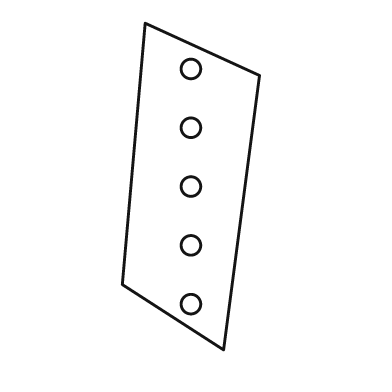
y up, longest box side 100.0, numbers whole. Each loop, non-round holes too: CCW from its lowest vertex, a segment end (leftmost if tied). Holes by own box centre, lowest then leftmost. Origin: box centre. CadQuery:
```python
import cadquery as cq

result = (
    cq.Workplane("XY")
    .moveTo(10.0, -50.0)
    .lineTo(21.0, 34.0)
    .lineTo(-14.0, 50.0)
    .lineTo(-21.0, -30.0)
    .close()
    .moveTo(0.0, -36.0)
    .circle(3.0)
    .moveTo(0.0, -18.0)
    .circle(3.0)
    .moveTo(0.0, 0.0)
    .circle(3.0)
    .moveTo(0.0, 18.0)
    .circle(3.0)
    .moveTo(0.0, 36.0)
    .circle(3.0)
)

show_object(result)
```